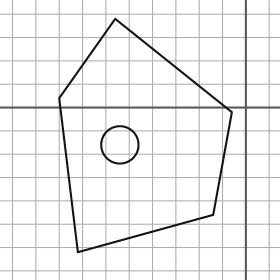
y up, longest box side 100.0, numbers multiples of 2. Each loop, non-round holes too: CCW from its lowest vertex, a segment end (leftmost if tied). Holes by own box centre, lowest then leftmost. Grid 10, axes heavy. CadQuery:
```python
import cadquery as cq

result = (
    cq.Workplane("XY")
    .moveTo(-72.0, -62.0)
    .lineTo(-14.0, -46.0)
    .lineTo(-6.0, -2.0)
    .lineTo(-56.0, 38.0)
    .lineTo(-80.0, 4.0)
    .close()
    .moveTo(-54.0, -16.0)
    .circle(8.0)
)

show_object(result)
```